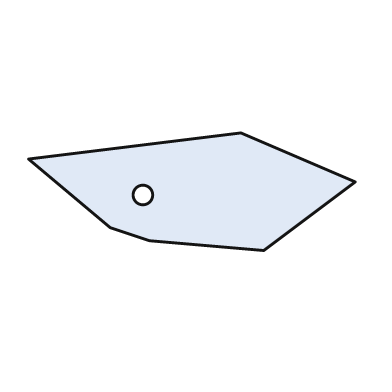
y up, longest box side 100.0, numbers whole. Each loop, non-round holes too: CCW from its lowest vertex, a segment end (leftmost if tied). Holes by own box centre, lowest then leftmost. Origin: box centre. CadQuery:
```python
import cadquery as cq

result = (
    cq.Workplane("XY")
    .moveTo(22.0, -18.0)
    .lineTo(50.0, 3.0)
    .lineTo(15.0, 18.0)
    .lineTo(-50.0, 10.0)
    .lineTo(-25.0, -11.0)
    .lineTo(-13.0, -15.0)
    .close()
    .moveTo(-15.0, -1.0)
    .circle(3.0)
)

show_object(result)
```